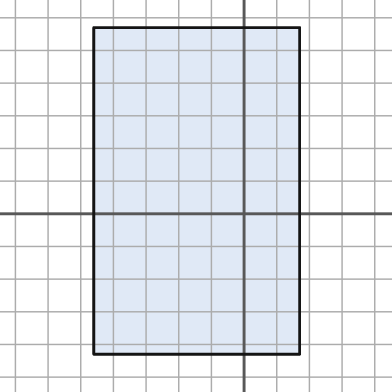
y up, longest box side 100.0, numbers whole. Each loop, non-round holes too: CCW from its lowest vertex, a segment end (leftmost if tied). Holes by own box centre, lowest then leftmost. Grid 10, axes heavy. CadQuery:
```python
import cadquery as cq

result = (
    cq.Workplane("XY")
    .moveTo(-46.0, -43.0)
    .lineTo(17.0, -43.0)
    .lineTo(17.0, 57.0)
    .lineTo(-46.0, 57.0)
    .close()
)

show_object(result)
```